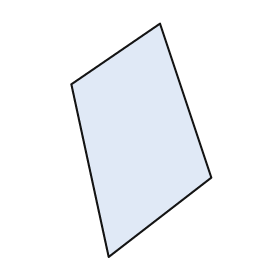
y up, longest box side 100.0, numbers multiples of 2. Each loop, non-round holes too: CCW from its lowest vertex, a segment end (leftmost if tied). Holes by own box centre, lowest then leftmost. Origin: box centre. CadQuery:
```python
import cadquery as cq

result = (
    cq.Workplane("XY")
    .moveTo(-14.0, -50.0)
    .lineTo(30.0, -16.0)
    .lineTo(8.0, 50.0)
    .lineTo(-30.0, 24.0)
    .close()
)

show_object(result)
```